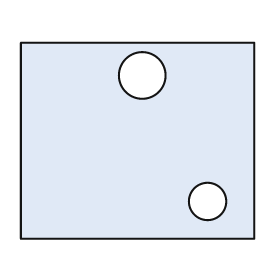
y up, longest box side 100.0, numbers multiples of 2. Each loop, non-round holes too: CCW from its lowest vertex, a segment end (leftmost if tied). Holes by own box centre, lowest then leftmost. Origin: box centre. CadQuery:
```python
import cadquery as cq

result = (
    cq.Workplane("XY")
    .moveTo(-50.0, -42.0)
    .lineTo(50.0, -42.0)
    .lineTo(50.0, 42.0)
    .lineTo(-50.0, 42.0)
    .close()
    .moveTo(30.0, -26.0)
    .circle(8.0)
    .moveTo(2.0, 28.0)
    .circle(10.0)
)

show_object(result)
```